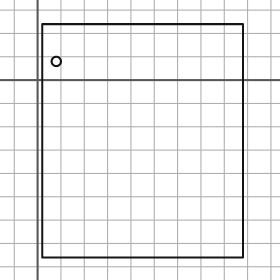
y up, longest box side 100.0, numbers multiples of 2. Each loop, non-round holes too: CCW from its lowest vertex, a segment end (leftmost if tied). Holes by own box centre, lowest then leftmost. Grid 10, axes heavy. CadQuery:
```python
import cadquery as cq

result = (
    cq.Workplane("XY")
    .moveTo(2.0, -76.0)
    .lineTo(88.0, -76.0)
    .lineTo(88.0, 24.0)
    .lineTo(2.0, 24.0)
    .close()
    .moveTo(8.0, 8.0)
    .circle(2.0)
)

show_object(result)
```